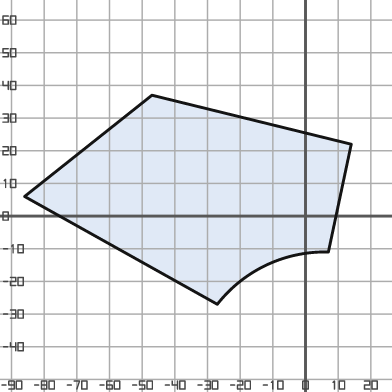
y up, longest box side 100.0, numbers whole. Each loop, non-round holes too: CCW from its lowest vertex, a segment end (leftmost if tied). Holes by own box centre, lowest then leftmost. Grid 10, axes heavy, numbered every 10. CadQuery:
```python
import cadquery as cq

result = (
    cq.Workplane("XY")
    .moveTo(-27.0, -27.0)
    .threePointArc((-12.0, -15.0), (7.0, -11.0))
    .lineTo(14.0, 22.0)
    .lineTo(-47.0, 37.0)
    .lineTo(-86.0, 6.0)
    .close()
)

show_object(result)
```